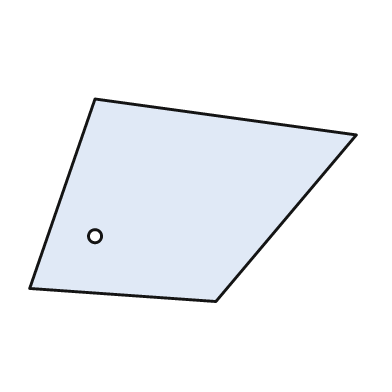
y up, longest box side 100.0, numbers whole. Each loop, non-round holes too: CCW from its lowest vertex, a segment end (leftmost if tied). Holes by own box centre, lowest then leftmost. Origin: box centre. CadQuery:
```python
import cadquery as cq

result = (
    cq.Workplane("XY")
    .moveTo(7.0, -31.0)
    .lineTo(50.0, 20.0)
    .lineTo(-30.0, 31.0)
    .lineTo(-50.0, -27.0)
    .close()
    .moveTo(-30.0, -11.0)
    .circle(2.0)
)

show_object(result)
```